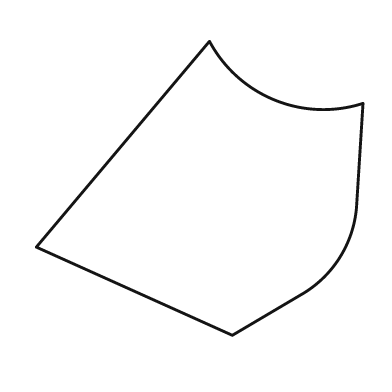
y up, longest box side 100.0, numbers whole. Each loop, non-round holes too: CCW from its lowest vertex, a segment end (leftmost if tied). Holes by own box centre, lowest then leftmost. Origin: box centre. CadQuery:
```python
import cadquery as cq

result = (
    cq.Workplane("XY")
    .moveTo(10.0, -45.0)
    .lineTo(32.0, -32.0)
    .threePointArc((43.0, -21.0), (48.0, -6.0))
    .lineTo(50.0, 26.0)
    .threePointArc((23.0, 27.0), (3.0, 45.0))
    .lineTo(-50.0, -18.0)
    .close()
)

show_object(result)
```